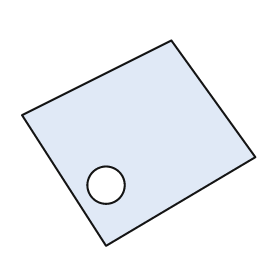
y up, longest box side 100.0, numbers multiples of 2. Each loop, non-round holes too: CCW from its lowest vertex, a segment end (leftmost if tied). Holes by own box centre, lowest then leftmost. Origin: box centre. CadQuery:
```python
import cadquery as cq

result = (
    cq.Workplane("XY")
    .moveTo(-14.0, -44.0)
    .lineTo(50.0, -6.0)
    .lineTo(14.0, 44.0)
    .lineTo(-50.0, 12.0)
    .close()
    .moveTo(-14.0, -18.0)
    .circle(8.0)
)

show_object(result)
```